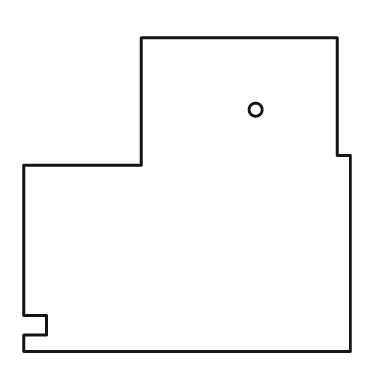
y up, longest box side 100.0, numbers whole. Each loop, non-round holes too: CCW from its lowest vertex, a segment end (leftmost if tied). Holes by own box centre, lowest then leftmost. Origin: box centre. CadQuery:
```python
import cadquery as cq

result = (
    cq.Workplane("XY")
    .moveTo(-50.0, -48.0)
    .lineTo(50.0, -48.0)
    .lineTo(50.0, 12.0)
    .lineTo(46.0, 12.0)
    .lineTo(46.0, 48.0)
    .lineTo(-14.0, 48.0)
    .lineTo(-14.0, 9.0)
    .lineTo(-50.0, 9.0)
    .lineTo(-50.0, -37.0)
    .lineTo(-43.0, -37.0)
    .lineTo(-43.0, -43.0)
    .lineTo(-50.0, -43.0)
    .close()
    .moveTo(21.0, 26.0)
    .circle(2.0)
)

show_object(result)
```